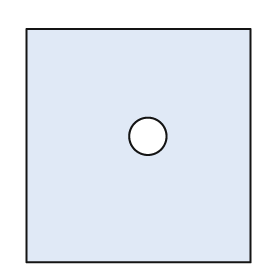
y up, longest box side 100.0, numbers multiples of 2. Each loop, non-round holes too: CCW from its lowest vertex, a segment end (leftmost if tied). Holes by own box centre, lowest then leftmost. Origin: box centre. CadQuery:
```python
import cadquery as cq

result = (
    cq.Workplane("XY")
    .moveTo(-48.0, -50.0)
    .lineTo(48.0, -50.0)
    .lineTo(48.0, 50.0)
    .lineTo(-48.0, 50.0)
    .close()
    .moveTo(4.0, 4.0)
    .circle(8.0)
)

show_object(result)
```